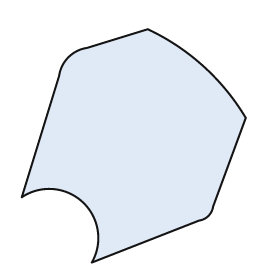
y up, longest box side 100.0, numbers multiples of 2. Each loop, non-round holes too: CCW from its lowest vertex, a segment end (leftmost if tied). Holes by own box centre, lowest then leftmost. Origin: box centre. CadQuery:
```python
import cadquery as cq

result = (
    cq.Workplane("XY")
    .moveTo(-18.0, -50.0)
    .lineTo(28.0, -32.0)
    .threePointArc((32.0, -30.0), (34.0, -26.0))
    .lineTo(48.0, 12.0)
    .threePointArc((30.0, 34.0), (6.0, 50.0))
    .lineTo(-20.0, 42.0)
    .threePointArc((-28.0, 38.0), (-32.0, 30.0))
    .lineTo(-48.0, -22.0)
    .threePointArc((-22.0, -24.0), (-18.0, -50.0))
    .close()
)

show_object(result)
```